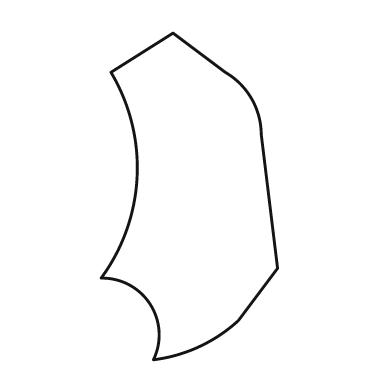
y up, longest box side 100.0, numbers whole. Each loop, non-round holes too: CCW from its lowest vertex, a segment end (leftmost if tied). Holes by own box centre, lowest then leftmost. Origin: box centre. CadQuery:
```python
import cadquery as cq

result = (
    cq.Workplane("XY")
    .moveTo(-11.0, -50.0)
    .threePointArc((3.0, -46.0), (15.0, -38.0))
    .lineTo(27.0, -22.0)
    .lineTo(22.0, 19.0)
    .threePointArc((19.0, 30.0), (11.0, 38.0))
    .lineTo(-5.0, 50.0)
    .lineTo(-24.0, 38.0)
    .threePointArc((-16.0, 6.0), (-27.0, -25.0))
    .threePointArc((-12.0, -33.0), (-11.0, -50.0))
    .close()
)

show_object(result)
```